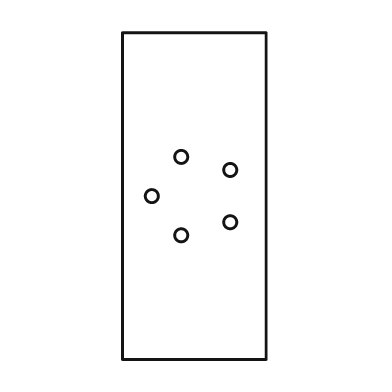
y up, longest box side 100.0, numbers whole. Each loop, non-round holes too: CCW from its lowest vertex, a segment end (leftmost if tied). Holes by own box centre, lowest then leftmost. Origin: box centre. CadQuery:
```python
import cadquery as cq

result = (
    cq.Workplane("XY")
    .moveTo(-22.0, -50.0)
    .lineTo(22.0, -50.0)
    .lineTo(22.0, 50.0)
    .lineTo(-22.0, 50.0)
    .close()
    .moveTo(-4.0, -12.0)
    .circle(2.0)
    .moveTo(11.0, -8.0)
    .circle(2.0)
    .moveTo(-13.0, 0.0)
    .circle(2.0)
    .moveTo(11.0, 8.0)
    .circle(2.0)
    .moveTo(-4.0, 12.0)
    .circle(2.0)
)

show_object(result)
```